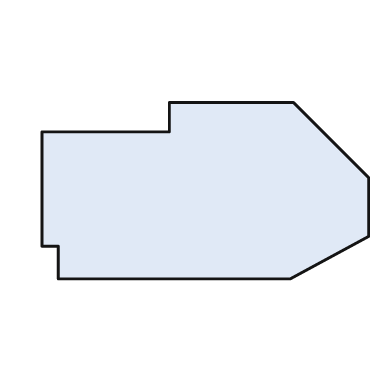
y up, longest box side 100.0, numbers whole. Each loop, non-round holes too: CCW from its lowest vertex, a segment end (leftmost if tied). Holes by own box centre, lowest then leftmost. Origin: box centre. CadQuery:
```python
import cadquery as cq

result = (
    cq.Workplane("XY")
    .moveTo(-45.0, -27.0)
    .lineTo(26.0, -27.0)
    .lineTo(50.0, -14.0)
    .lineTo(50.0, 4.0)
    .lineTo(27.0, 27.0)
    .lineTo(-11.0, 27.0)
    .lineTo(-11.0, 18.0)
    .lineTo(-50.0, 18.0)
    .lineTo(-50.0, -17.0)
    .lineTo(-45.0, -17.0)
    .close()
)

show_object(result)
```